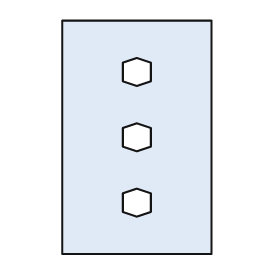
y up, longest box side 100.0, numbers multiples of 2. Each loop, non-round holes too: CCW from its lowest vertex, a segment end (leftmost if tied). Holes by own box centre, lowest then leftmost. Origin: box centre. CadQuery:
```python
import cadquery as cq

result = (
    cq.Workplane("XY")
    .moveTo(-32.0, -50.0)
    .lineTo(32.0, -50.0)
    .lineTo(32.0, 50.0)
    .lineTo(-32.0, 50.0)
    .close()
    .moveTo(0.0, -34.0)
    .lineTo(6.0, -32.0)
    .lineTo(6.0, -24.0)
    .lineTo(0.0, -22.0)
    .lineTo(-6.0, -24.0)
    .lineTo(-6.0, -32.0)
    .close()
    .moveTo(0.0, -6.0)
    .lineTo(6.0, -4.0)
    .lineTo(6.0, 4.0)
    .lineTo(0.0, 6.0)
    .lineTo(-6.0, 4.0)
    .lineTo(-6.0, -4.0)
    .close()
    .moveTo(0.0, 22.0)
    .lineTo(6.0, 24.0)
    .lineTo(6.0, 32.0)
    .lineTo(0.0, 34.0)
    .lineTo(-6.0, 32.0)
    .lineTo(-6.0, 24.0)
    .close()
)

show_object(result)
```